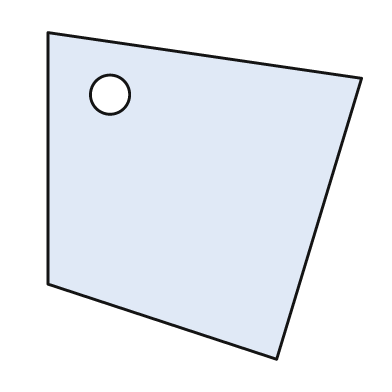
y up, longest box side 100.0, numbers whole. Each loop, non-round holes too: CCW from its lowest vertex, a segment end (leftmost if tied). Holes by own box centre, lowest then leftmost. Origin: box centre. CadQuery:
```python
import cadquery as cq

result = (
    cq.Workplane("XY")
    .moveTo(22.0, -50.0)
    .lineTo(48.0, 36.0)
    .lineTo(-48.0, 50.0)
    .lineTo(-48.0, -27.0)
    .close()
    .moveTo(-29.0, 31.0)
    .circle(6.0)
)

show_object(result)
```